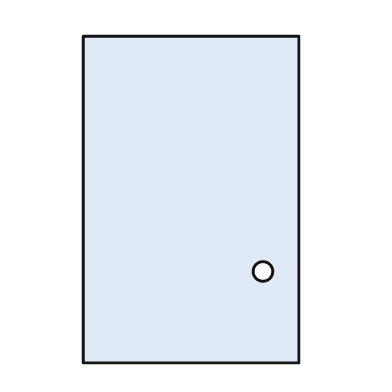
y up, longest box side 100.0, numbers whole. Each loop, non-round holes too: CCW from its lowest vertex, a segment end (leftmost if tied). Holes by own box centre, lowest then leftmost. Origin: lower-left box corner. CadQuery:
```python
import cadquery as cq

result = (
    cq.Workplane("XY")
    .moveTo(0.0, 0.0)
    .lineTo(66.0, 0.0)
    .lineTo(66.0, 100.0)
    .lineTo(0.0, 100.0)
    .close()
    .moveTo(55.0, 28.0)
    .circle(3.0)
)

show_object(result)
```